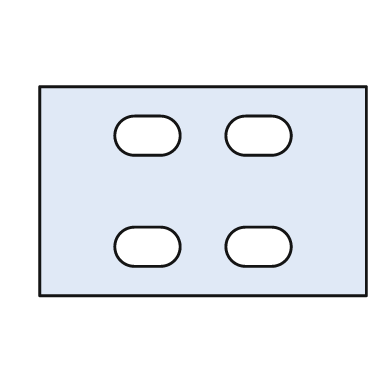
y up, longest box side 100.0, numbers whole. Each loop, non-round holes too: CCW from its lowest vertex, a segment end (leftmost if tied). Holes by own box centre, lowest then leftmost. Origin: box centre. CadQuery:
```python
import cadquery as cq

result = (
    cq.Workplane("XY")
    .moveTo(-50.0, -32.0)
    .lineTo(50.0, -32.0)
    .lineTo(50.0, 32.0)
    .lineTo(-50.0, 32.0)
    .close()
    .moveTo(-21.0, -23.0)
    .lineTo(-13.0, -23.0)
    .threePointArc((-7.0, -17.0), (-13.0, -11.0))
    .lineTo(-21.0, -11.0)
    .threePointArc((-27.0, -17.0), (-21.0, -23.0))
    .close()
    .moveTo(13.0, -23.0)
    .lineTo(21.0, -23.0)
    .threePointArc((27.0, -17.0), (21.0, -11.0))
    .lineTo(13.0, -11.0)
    .threePointArc((7.0, -17.0), (13.0, -23.0))
    .close()
    .moveTo(-21.0, 11.0)
    .lineTo(-13.0, 11.0)
    .threePointArc((-7.0, 17.0), (-13.0, 23.0))
    .lineTo(-21.0, 23.0)
    .threePointArc((-27.0, 17.0), (-21.0, 11.0))
    .close()
    .moveTo(13.0, 11.0)
    .lineTo(21.0, 11.0)
    .threePointArc((27.0, 17.0), (21.0, 23.0))
    .lineTo(13.0, 23.0)
    .threePointArc((7.0, 17.0), (13.0, 11.0))
    .close()
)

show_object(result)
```